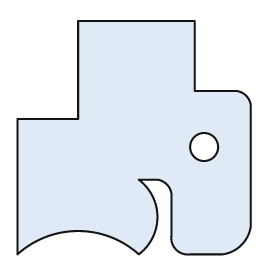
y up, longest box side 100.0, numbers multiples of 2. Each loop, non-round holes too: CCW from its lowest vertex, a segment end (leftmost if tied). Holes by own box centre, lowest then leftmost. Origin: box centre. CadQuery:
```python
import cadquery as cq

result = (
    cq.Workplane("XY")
    .moveTo(-50.0, -50.0)
    .threePointArc((-24.0, -40.0), (2.0, -50.0))
    .threePointArc((10.0, -34.0), (2.0, -18.0))
    .lineTo(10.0, -18.0)
    .threePointArc((14.0, -20.0), (16.0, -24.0))
    .lineTo(16.0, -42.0)
    .threePointArc((18.0, -48.0), (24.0, -50.0))
    .lineTo(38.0, -50.0)
    .threePointArc((46.0, -46.0), (50.0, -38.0))
    .lineTo(50.0, 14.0)
    .threePointArc((48.0, 18.0), (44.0, 20.0))
    .lineTo(26.0, 20.0)
    .lineTo(26.0, 50.0)
    .lineTo(-24.0, 50.0)
    .lineTo(-24.0, 8.0)
    .lineTo(-50.0, 8.0)
    .close()
    .moveTo(30.0, -4.0)
    .circle(6.0)
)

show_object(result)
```